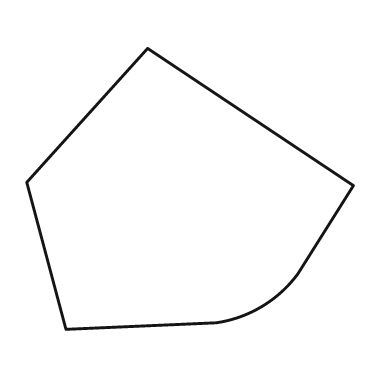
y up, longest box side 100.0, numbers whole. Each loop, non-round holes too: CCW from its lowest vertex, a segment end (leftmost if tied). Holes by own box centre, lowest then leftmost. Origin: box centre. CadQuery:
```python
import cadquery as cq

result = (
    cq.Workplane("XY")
    .moveTo(-38.0, -43.0)
    .lineTo(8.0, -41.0)
    .threePointArc((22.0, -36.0), (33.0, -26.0))
    .lineTo(50.0, 1.0)
    .lineTo(-13.0, 43.0)
    .lineTo(-50.0, 2.0)
    .close()
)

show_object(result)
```